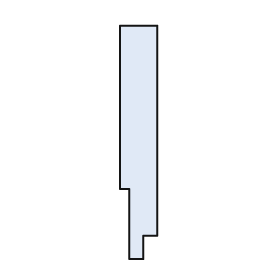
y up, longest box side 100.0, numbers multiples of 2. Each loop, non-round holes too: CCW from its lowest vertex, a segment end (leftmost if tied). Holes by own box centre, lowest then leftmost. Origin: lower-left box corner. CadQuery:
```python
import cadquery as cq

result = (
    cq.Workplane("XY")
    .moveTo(4.0, 0.0)
    .lineTo(10.0, 0.0)
    .lineTo(10.0, 10.0)
    .lineTo(16.0, 10.0)
    .lineTo(16.0, 100.0)
    .lineTo(0.0, 100.0)
    .lineTo(0.0, 30.0)
    .lineTo(4.0, 30.0)
    .close()
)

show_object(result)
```